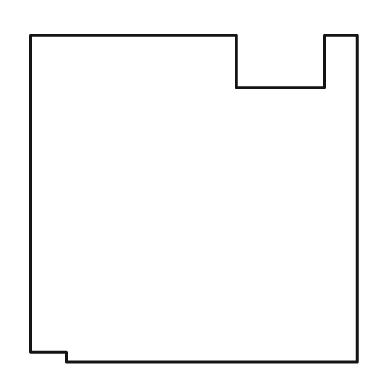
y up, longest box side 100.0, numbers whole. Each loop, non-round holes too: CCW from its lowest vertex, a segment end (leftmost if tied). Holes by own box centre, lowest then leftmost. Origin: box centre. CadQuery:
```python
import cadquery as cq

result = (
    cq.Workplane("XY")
    .moveTo(-39.0, -50.0)
    .lineTo(50.0, -50.0)
    .lineTo(50.0, 50.0)
    .lineTo(40.0, 50.0)
    .lineTo(40.0, 34.0)
    .lineTo(13.0, 34.0)
    .lineTo(13.0, 50.0)
    .lineTo(-50.0, 50.0)
    .lineTo(-50.0, -47.0)
    .lineTo(-39.0, -47.0)
    .close()
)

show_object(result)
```